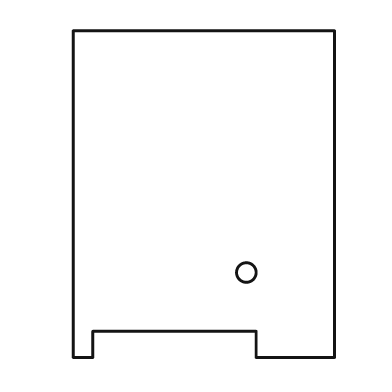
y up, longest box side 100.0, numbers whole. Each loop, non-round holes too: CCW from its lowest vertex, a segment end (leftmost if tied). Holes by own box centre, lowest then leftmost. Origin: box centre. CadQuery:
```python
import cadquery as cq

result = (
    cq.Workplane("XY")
    .moveTo(-40.0, -50.0)
    .lineTo(-34.0, -50.0)
    .lineTo(-34.0, -42.0)
    .lineTo(16.0, -42.0)
    .lineTo(16.0, -50.0)
    .lineTo(40.0, -50.0)
    .lineTo(40.0, 50.0)
    .lineTo(-40.0, 50.0)
    .close()
    .moveTo(13.0, -24.0)
    .circle(3.0)
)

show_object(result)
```